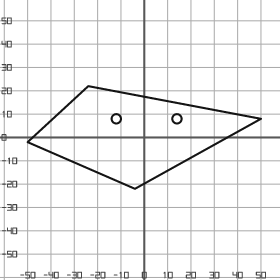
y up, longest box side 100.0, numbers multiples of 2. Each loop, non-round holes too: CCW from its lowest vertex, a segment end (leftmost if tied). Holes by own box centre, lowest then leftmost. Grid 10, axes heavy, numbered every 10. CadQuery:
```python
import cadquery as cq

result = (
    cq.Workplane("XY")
    .moveTo(-4.0, -22.0)
    .lineTo(50.0, 8.0)
    .lineTo(-24.0, 22.0)
    .lineTo(-50.0, -2.0)
    .close()
    .moveTo(-12.0, 8.0)
    .circle(2.0)
    .moveTo(14.0, 8.0)
    .circle(2.0)
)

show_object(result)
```